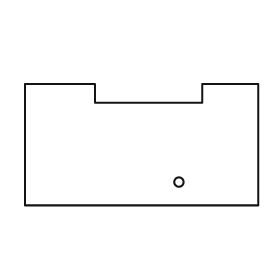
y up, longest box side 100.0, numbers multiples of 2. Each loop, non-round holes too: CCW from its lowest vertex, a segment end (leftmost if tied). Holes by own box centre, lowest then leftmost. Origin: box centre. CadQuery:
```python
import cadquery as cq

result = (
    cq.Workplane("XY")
    .moveTo(-50.0, -26.0)
    .lineTo(50.0, -26.0)
    .lineTo(50.0, 26.0)
    .lineTo(26.0, 26.0)
    .lineTo(26.0, 18.0)
    .lineTo(-20.0, 18.0)
    .lineTo(-20.0, 26.0)
    .lineTo(-50.0, 26.0)
    .close()
    .moveTo(16.0, -16.0)
    .circle(2.0)
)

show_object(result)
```